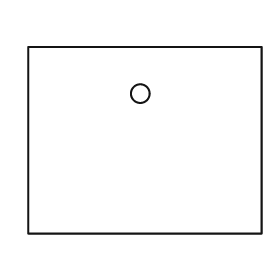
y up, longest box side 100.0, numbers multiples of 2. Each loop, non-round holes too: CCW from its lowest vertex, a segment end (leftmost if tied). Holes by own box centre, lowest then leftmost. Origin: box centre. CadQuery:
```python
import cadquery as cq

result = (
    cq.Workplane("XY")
    .moveTo(-50.0, -40.0)
    .lineTo(50.0, -40.0)
    .lineTo(50.0, 40.0)
    .lineTo(-50.0, 40.0)
    .close()
    .moveTo(-2.0, 20.0)
    .circle(4.0)
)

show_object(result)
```